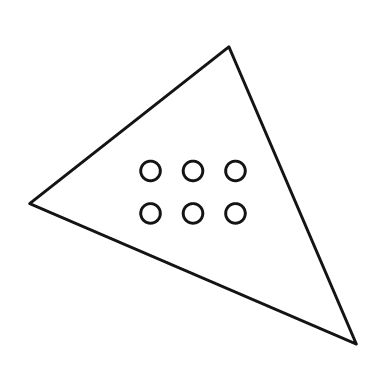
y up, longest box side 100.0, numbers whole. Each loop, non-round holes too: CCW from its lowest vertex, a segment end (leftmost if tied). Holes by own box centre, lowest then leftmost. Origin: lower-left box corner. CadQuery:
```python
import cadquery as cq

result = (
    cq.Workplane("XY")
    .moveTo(100.0, 0.0)
    .lineTo(61.0, 91.0)
    .lineTo(0.0, 43.0)
    .close()
    .moveTo(37.0, 40.0)
    .circle(3.0)
    .moveTo(50.0, 40.0)
    .circle(3.0)
    .moveTo(63.0, 40.0)
    .circle(3.0)
    .moveTo(37.0, 53.0)
    .circle(3.0)
    .moveTo(50.0, 53.0)
    .circle(3.0)
    .moveTo(63.0, 53.0)
    .circle(3.0)
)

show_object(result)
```